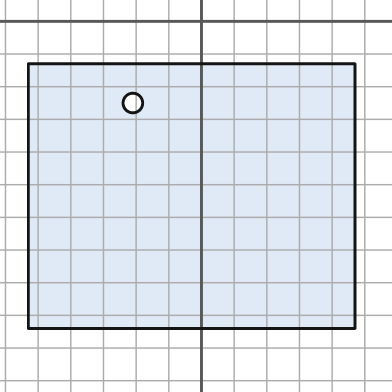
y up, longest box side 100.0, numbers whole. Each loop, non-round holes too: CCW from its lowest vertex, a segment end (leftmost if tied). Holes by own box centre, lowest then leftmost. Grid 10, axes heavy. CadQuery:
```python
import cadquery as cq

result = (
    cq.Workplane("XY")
    .moveTo(-53.0, -94.0)
    .lineTo(47.0, -94.0)
    .lineTo(47.0, -13.0)
    .lineTo(-53.0, -13.0)
    .close()
    .moveTo(-21.0, -25.0)
    .circle(3.0)
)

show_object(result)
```